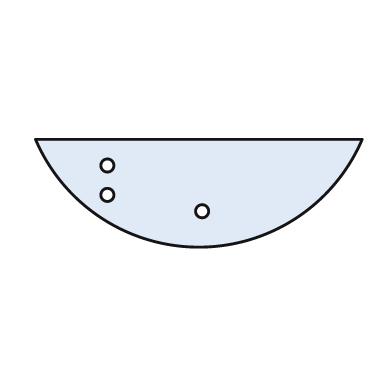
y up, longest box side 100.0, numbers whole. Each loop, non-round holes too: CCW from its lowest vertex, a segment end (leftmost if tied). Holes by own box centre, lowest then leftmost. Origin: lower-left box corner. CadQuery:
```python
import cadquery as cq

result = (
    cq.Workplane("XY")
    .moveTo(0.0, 33.0)
    .threePointArc((50.0, 0.0), (100.0, 33.0))
    .close()
    .moveTo(51.0, 11.0)
    .circle(2.0)
    .moveTo(22.0, 16.0)
    .circle(2.0)
    .moveTo(22.0, 25.0)
    .circle(2.0)
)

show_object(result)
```